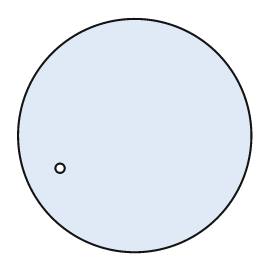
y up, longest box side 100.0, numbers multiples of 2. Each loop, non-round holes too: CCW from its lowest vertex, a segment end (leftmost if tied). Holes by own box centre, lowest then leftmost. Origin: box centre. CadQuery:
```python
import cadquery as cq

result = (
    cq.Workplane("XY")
    .moveTo(0.0, 0.0)
    .circle(50.0)
    .moveTo(-32.0, -14.0)
    .circle(2.0)
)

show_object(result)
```